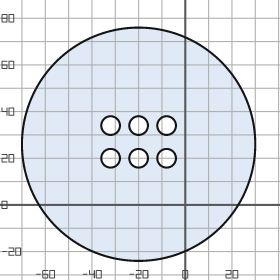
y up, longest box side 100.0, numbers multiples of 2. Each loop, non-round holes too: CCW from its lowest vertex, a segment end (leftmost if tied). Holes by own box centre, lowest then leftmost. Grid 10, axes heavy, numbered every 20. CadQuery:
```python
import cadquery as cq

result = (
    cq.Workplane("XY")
    .moveTo(-20.0, 26.0)
    .circle(50.0)
    .moveTo(-32.0, 20.0)
    .circle(4.0)
    .moveTo(-20.0, 20.0)
    .circle(4.0)
    .moveTo(-8.0, 20.0)
    .circle(4.0)
    .moveTo(-32.0, 34.0)
    .circle(4.0)
    .moveTo(-20.0, 34.0)
    .circle(4.0)
    .moveTo(-8.0, 34.0)
    .circle(4.0)
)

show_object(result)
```